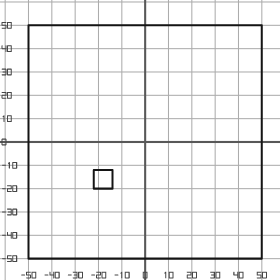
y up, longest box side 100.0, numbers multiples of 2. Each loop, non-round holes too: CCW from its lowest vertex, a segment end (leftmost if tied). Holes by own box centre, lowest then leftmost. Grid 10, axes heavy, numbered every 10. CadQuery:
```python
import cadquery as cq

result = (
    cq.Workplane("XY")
    .moveTo(-50.0, -50.0)
    .lineTo(50.0, -50.0)
    .lineTo(50.0, 50.0)
    .lineTo(-50.0, 50.0)
    .close()
    .moveTo(-22.0, -20.0)
    .lineTo(-14.0, -20.0)
    .lineTo(-14.0, -12.0)
    .lineTo(-22.0, -12.0)
    .close()
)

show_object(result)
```